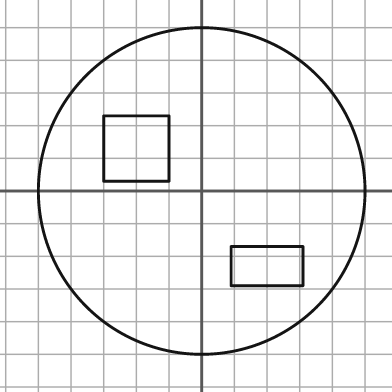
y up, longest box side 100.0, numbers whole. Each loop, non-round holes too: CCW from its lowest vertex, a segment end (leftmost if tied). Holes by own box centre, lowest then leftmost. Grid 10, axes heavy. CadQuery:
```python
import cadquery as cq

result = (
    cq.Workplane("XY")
    .moveTo(0.0, 0.0)
    .circle(50.0)
    .moveTo(9.0, -29.0)
    .lineTo(31.0, -29.0)
    .lineTo(31.0, -17.0)
    .lineTo(9.0, -17.0)
    .close()
    .moveTo(-30.0, 3.0)
    .lineTo(-10.0, 3.0)
    .lineTo(-10.0, 23.0)
    .lineTo(-30.0, 23.0)
    .close()
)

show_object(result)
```